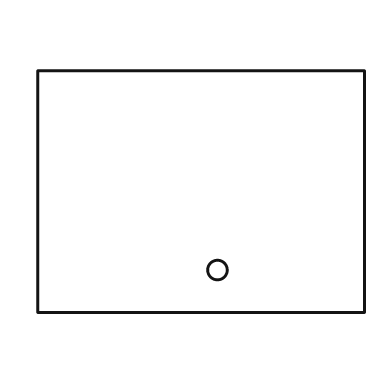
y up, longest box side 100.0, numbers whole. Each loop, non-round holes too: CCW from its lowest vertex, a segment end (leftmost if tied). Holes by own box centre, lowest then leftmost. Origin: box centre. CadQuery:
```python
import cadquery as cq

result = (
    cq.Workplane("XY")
    .moveTo(-50.0, -37.0)
    .lineTo(50.0, -37.0)
    .lineTo(50.0, 37.0)
    .lineTo(-50.0, 37.0)
    .close()
    .moveTo(5.0, -24.0)
    .circle(3.0)
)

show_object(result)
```